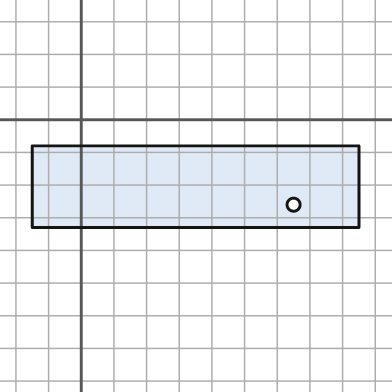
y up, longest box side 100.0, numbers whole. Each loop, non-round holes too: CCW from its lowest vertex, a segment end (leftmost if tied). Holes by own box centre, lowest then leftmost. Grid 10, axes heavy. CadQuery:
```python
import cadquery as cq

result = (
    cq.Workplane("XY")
    .moveTo(-15.0, -33.0)
    .lineTo(85.0, -33.0)
    .lineTo(85.0, -8.0)
    .lineTo(-15.0, -8.0)
    .close()
    .moveTo(65.0, -26.0)
    .circle(2.0)
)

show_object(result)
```